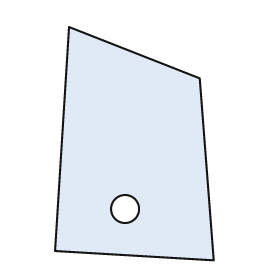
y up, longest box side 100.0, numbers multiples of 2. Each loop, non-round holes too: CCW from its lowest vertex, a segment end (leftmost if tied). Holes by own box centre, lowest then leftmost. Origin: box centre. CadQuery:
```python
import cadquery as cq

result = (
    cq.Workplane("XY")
    .moveTo(34.0, -50.0)
    .lineTo(28.0, 28.0)
    .lineTo(-28.0, 50.0)
    .lineTo(-34.0, -46.0)
    .close()
    .moveTo(-4.0, -28.0)
    .circle(6.0)
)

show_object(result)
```